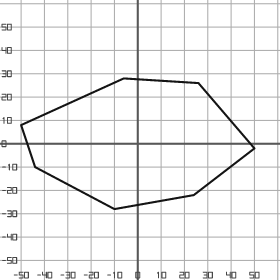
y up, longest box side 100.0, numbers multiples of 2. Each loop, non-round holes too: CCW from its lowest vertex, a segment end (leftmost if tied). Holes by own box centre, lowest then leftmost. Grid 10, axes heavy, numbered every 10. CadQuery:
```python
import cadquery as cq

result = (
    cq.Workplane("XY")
    .moveTo(-10.0, -28.0)
    .lineTo(24.0, -22.0)
    .lineTo(50.0, -2.0)
    .lineTo(26.0, 26.0)
    .lineTo(-6.0, 28.0)
    .lineTo(-50.0, 8.0)
    .lineTo(-44.0, -10.0)
    .close()
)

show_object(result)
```